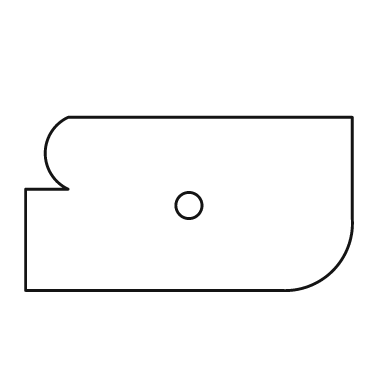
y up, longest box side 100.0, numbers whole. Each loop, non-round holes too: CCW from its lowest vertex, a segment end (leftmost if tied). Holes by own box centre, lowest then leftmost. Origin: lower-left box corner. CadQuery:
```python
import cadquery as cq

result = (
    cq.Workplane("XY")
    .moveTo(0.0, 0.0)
    .lineTo(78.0, 0.0)
    .threePointArc((94.0, 6.0), (100.0, 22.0))
    .lineTo(100.0, 53.0)
    .lineTo(13.0, 53.0)
    .threePointArc((6.0, 42.0), (13.0, 31.0))
    .lineTo(0.0, 31.0)
    .close()
    .moveTo(50.0, 26.0)
    .circle(4.0)
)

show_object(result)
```